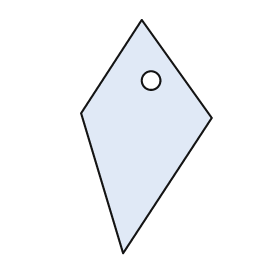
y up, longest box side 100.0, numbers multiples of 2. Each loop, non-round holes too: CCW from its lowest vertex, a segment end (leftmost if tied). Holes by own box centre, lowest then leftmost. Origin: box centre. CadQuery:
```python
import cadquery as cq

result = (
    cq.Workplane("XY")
    .moveTo(-10.0, -50.0)
    .lineTo(28.0, 8.0)
    .lineTo(-2.0, 50.0)
    .lineTo(-28.0, 10.0)
    .close()
    .moveTo(2.0, 24.0)
    .circle(4.0)
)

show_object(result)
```